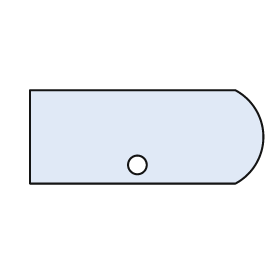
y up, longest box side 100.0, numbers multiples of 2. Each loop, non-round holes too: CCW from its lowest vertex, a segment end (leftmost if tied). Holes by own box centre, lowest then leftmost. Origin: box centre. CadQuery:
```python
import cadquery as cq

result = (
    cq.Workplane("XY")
    .moveTo(-50.0, -20.0)
    .lineTo(38.0, -20.0)
    .threePointArc((50.0, 0.0), (38.0, 20.0))
    .lineTo(-50.0, 20.0)
    .close()
    .moveTo(-4.0, -12.0)
    .circle(4.0)
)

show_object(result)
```